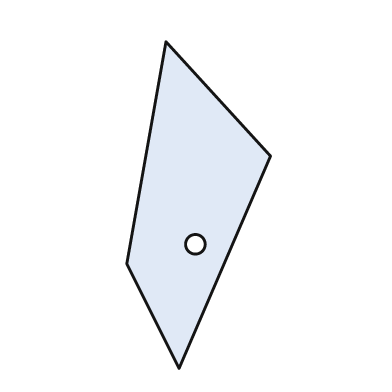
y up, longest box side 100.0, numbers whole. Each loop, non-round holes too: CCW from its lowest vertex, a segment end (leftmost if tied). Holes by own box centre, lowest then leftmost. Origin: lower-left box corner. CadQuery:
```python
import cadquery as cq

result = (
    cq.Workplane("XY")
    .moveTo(16.0, 0.0)
    .lineTo(44.0, 65.0)
    .lineTo(12.0, 100.0)
    .lineTo(0.0, 32.0)
    .close()
    .moveTo(21.0, 38.0)
    .circle(3.0)
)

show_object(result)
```